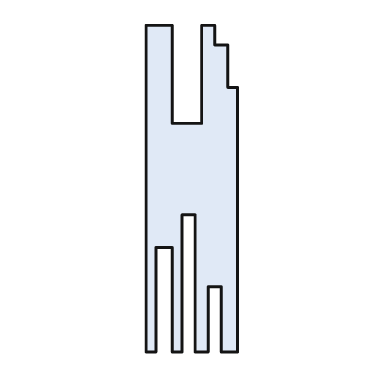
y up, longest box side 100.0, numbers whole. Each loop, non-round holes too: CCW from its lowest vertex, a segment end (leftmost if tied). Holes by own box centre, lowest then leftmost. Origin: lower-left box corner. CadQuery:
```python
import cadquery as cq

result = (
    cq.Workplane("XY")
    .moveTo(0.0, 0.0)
    .lineTo(3.0, 0.0)
    .lineTo(3.0, 32.0)
    .lineTo(8.0, 32.0)
    .lineTo(8.0, 0.0)
    .lineTo(11.0, 0.0)
    .lineTo(11.0, 42.0)
    .lineTo(15.0, 42.0)
    .lineTo(15.0, 0.0)
    .lineTo(19.0, 0.0)
    .lineTo(19.0, 20.0)
    .lineTo(23.0, 20.0)
    .lineTo(23.0, 0.0)
    .lineTo(28.0, 0.0)
    .lineTo(28.0, 81.0)
    .lineTo(25.0, 81.0)
    .lineTo(25.0, 94.0)
    .lineTo(21.0, 94.0)
    .lineTo(21.0, 100.0)
    .lineTo(17.0, 100.0)
    .lineTo(17.0, 70.0)
    .lineTo(8.0, 70.0)
    .lineTo(8.0, 100.0)
    .lineTo(0.0, 100.0)
    .close()
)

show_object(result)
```